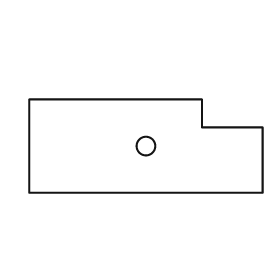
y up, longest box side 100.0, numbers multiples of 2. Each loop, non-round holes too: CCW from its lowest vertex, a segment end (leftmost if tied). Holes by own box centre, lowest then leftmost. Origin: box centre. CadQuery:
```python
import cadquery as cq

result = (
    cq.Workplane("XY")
    .moveTo(-50.0, -20.0)
    .lineTo(50.0, -20.0)
    .lineTo(50.0, 8.0)
    .lineTo(24.0, 8.0)
    .lineTo(24.0, 20.0)
    .lineTo(-50.0, 20.0)
    .close()
    .moveTo(0.0, 0.0)
    .circle(4.0)
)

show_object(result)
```